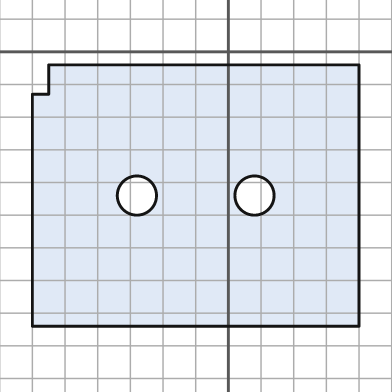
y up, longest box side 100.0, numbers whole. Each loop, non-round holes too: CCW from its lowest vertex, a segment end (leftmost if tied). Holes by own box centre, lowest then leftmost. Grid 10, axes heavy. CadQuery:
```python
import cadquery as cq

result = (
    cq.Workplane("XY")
    .moveTo(-60.0, -84.0)
    .lineTo(40.0, -84.0)
    .lineTo(40.0, -4.0)
    .lineTo(-55.0, -4.0)
    .lineTo(-55.0, -13.0)
    .lineTo(-60.0, -13.0)
    .close()
    .moveTo(-28.0, -44.0)
    .circle(6.0)
    .moveTo(8.0, -44.0)
    .circle(6.0)
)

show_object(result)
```